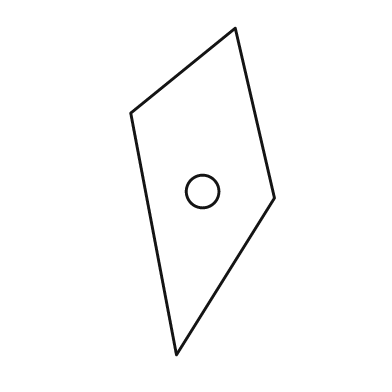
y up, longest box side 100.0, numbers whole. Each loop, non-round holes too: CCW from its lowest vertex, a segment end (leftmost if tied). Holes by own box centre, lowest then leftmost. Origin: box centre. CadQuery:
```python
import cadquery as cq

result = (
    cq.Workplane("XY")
    .moveTo(-8.0, -50.0)
    .lineTo(22.0, -2.0)
    .lineTo(10.0, 50.0)
    .lineTo(-22.0, 24.0)
    .close()
    .moveTo(0.0, 0.0)
    .circle(5.0)
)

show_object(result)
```